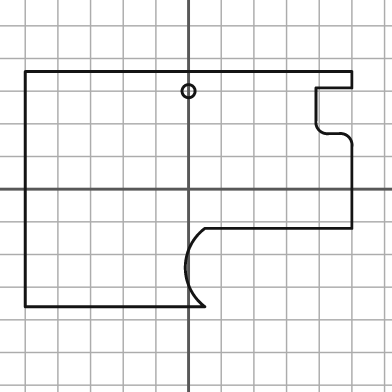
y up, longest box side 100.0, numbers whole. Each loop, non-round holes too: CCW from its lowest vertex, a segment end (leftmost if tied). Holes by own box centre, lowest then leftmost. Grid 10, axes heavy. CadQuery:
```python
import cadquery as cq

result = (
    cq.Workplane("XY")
    .moveTo(-50.0, -36.0)
    .lineTo(5.0, -36.0)
    .threePointArc((-1.0, -24.0), (5.0, -12.0))
    .lineTo(50.0, -12.0)
    .lineTo(50.0, 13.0)
    .threePointArc((49.0, 16.0), (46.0, 17.0))
    .lineTo(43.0, 17.0)
    .threePointArc((40.0, 18.0), (39.0, 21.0))
    .lineTo(39.0, 31.0)
    .lineTo(50.0, 31.0)
    .lineTo(50.0, 36.0)
    .lineTo(-50.0, 36.0)
    .close()
    .moveTo(0.0, 30.0)
    .circle(2.0)
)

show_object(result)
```